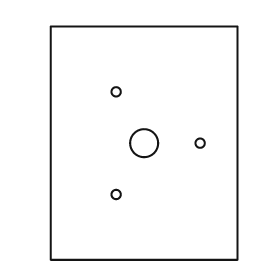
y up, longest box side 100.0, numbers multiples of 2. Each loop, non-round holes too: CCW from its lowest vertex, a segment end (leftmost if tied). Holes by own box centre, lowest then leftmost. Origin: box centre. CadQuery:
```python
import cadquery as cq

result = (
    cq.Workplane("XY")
    .moveTo(-40.0, -50.0)
    .lineTo(40.0, -50.0)
    .lineTo(40.0, 50.0)
    .lineTo(-40.0, 50.0)
    .close()
    .moveTo(-12.0, -22.0)
    .circle(2.0)
    .moveTo(0.0, 0.0)
    .circle(6.0)
    .moveTo(24.0, 0.0)
    .circle(2.0)
    .moveTo(-12.0, 22.0)
    .circle(2.0)
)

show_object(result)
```